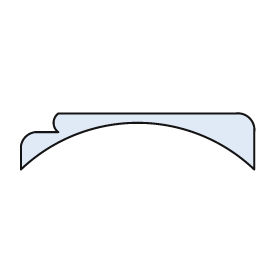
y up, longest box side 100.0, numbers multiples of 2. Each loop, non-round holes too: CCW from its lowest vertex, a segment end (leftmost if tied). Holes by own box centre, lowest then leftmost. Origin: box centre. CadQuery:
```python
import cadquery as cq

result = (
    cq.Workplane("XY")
    .moveTo(-50.0, -12.0)
    .threePointArc((0.0, 8.0), (50.0, -12.0))
    .lineTo(50.0, 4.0)
    .threePointArc((48.0, 10.0), (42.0, 12.0))
    .lineTo(-34.0, 12.0)
    .threePointArc((-36.0, 8.0), (-34.0, 4.0))
    .lineTo(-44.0, 4.0)
    .threePointArc((-48.0, 2.0), (-50.0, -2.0))
    .close()
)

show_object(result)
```